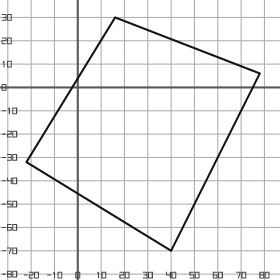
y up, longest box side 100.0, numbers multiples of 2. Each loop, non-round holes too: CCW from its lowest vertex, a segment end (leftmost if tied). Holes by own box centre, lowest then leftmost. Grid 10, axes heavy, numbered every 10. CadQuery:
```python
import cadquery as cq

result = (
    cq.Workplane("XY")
    .moveTo(40.0, -70.0)
    .lineTo(78.0, 6.0)
    .lineTo(16.0, 30.0)
    .lineTo(-22.0, -32.0)
    .close()
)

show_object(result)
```